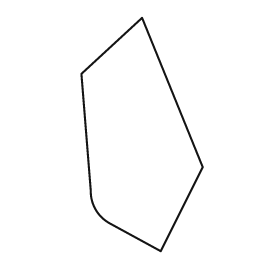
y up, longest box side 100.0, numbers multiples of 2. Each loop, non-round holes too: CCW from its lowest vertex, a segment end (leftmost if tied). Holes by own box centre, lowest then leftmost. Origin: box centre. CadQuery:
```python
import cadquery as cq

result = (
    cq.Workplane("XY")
    .moveTo(8.0, -50.0)
    .lineTo(26.0, -14.0)
    .lineTo(0.0, 50.0)
    .lineTo(-26.0, 26.0)
    .lineTo(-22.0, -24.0)
    .threePointArc((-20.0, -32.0), (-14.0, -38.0))
    .close()
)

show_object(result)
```